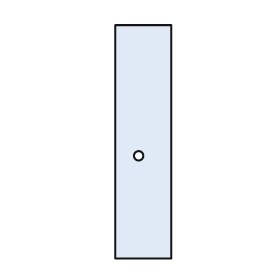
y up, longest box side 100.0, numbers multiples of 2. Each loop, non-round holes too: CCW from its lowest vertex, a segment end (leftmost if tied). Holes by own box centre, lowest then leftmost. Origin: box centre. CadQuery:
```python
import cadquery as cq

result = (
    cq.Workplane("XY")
    .moveTo(-12.0, -50.0)
    .lineTo(12.0, -50.0)
    .lineTo(12.0, 50.0)
    .lineTo(-12.0, 50.0)
    .close()
    .moveTo(-2.0, -6.0)
    .circle(2.0)
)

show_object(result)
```